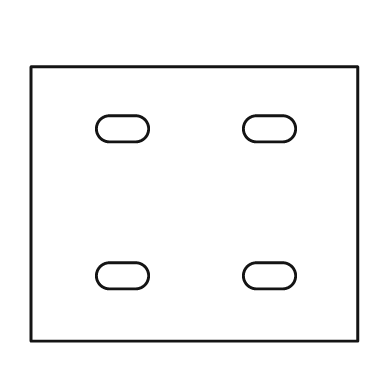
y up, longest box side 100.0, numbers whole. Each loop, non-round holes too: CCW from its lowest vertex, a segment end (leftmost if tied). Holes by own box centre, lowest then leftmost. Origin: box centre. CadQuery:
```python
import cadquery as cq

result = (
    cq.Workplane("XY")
    .moveTo(-50.0, -42.0)
    .lineTo(50.0, -42.0)
    .lineTo(50.0, 42.0)
    .lineTo(-50.0, 42.0)
    .close()
    .moveTo(-26.0, -26.0)
    .lineTo(-18.0, -26.0)
    .threePointArc((-14.0, -22.0), (-18.0, -18.0))
    .lineTo(-26.0, -18.0)
    .threePointArc((-30.0, -22.0), (-26.0, -26.0))
    .close()
    .moveTo(19.0, -26.0)
    .lineTo(27.0, -26.0)
    .threePointArc((31.0, -22.0), (27.0, -18.0))
    .lineTo(19.0, -18.0)
    .threePointArc((15.0, -22.0), (19.0, -26.0))
    .close()
    .moveTo(-26.0, 19.0)
    .lineTo(-18.0, 19.0)
    .threePointArc((-14.0, 23.0), (-18.0, 27.0))
    .lineTo(-26.0, 27.0)
    .threePointArc((-30.0, 23.0), (-26.0, 19.0))
    .close()
    .moveTo(19.0, 19.0)
    .lineTo(27.0, 19.0)
    .threePointArc((31.0, 23.0), (27.0, 27.0))
    .lineTo(19.0, 27.0)
    .threePointArc((15.0, 23.0), (19.0, 19.0))
    .close()
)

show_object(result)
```